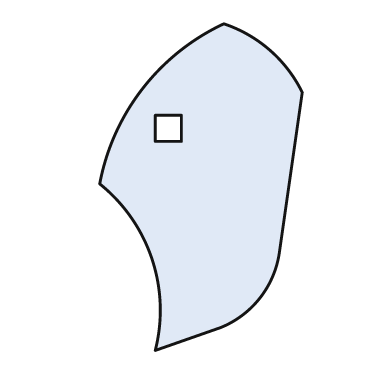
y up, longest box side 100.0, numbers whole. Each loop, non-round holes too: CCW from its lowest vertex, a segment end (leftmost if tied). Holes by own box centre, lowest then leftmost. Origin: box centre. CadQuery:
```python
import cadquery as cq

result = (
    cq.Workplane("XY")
    .moveTo(-14.0, -50.0)
    .lineTo(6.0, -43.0)
    .threePointArc((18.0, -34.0), (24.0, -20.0))
    .lineTo(31.0, 29.0)
    .threePointArc((21.0, 42.0), (7.0, 50.0))
    .threePointArc((-18.0, 30.0), (-31.0, 1.0))
    .threePointArc((-15.0, -22.0), (-14.0, -50.0))
    .close()
    .moveTo(-14.0, 14.0)
    .lineTo(-6.0, 14.0)
    .lineTo(-6.0, 22.0)
    .lineTo(-14.0, 22.0)
    .close()
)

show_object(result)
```